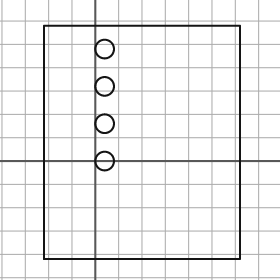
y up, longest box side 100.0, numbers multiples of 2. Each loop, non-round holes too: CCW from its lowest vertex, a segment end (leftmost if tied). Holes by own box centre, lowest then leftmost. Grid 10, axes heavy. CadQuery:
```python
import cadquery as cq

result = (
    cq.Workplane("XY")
    .moveTo(-22.0, -42.0)
    .lineTo(62.0, -42.0)
    .lineTo(62.0, 58.0)
    .lineTo(-22.0, 58.0)
    .close()
    .moveTo(4.0, 0.0)
    .circle(4.0)
    .moveTo(4.0, 16.0)
    .circle(4.0)
    .moveTo(4.0, 32.0)
    .circle(4.0)
    .moveTo(4.0, 48.0)
    .circle(4.0)
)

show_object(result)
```